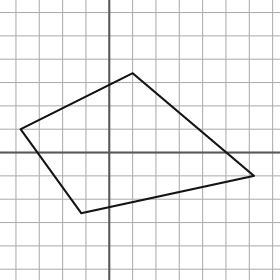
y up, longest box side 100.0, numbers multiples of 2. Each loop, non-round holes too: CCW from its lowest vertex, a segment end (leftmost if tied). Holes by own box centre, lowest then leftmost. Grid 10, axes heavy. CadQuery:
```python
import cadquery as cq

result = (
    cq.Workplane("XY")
    .moveTo(-12.0, -26.0)
    .lineTo(62.0, -10.0)
    .lineTo(10.0, 34.0)
    .lineTo(-38.0, 10.0)
    .close()
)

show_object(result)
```